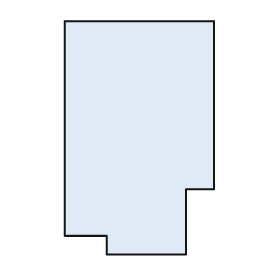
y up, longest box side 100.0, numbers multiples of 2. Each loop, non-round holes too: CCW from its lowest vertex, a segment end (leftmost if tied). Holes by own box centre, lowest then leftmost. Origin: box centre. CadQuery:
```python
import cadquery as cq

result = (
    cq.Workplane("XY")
    .moveTo(-14.0, -50.0)
    .lineTo(20.0, -50.0)
    .lineTo(20.0, -22.0)
    .lineTo(32.0, -22.0)
    .lineTo(32.0, 50.0)
    .lineTo(-32.0, 50.0)
    .lineTo(-32.0, -42.0)
    .lineTo(-14.0, -42.0)
    .close()
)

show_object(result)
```